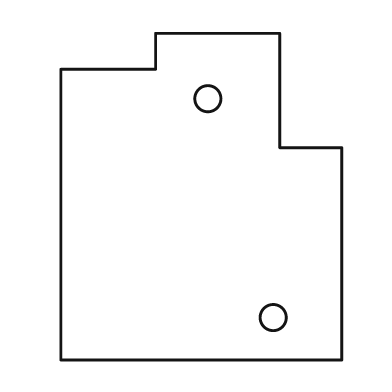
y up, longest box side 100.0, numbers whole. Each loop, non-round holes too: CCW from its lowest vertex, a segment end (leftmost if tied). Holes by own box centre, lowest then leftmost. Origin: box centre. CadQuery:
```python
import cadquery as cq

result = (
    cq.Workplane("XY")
    .moveTo(-43.0, -50.0)
    .lineTo(43.0, -50.0)
    .lineTo(43.0, 15.0)
    .lineTo(24.0, 15.0)
    .lineTo(24.0, 50.0)
    .lineTo(-14.0, 50.0)
    .lineTo(-14.0, 39.0)
    .lineTo(-43.0, 39.0)
    .close()
    .moveTo(22.0, -37.0)
    .circle(4.0)
    .moveTo(2.0, 30.0)
    .circle(4.0)
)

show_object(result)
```